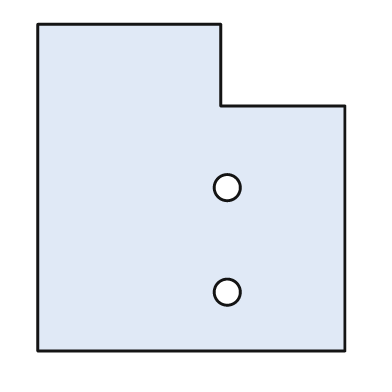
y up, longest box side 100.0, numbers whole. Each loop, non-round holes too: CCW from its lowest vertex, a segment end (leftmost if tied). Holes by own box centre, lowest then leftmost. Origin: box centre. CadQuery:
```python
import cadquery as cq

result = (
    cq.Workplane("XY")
    .moveTo(-47.0, -50.0)
    .lineTo(47.0, -50.0)
    .lineTo(47.0, 25.0)
    .lineTo(9.0, 25.0)
    .lineTo(9.0, 50.0)
    .lineTo(-47.0, 50.0)
    .close()
    .moveTo(11.0, -32.0)
    .circle(4.0)
    .moveTo(11.0, 0.0)
    .circle(4.0)
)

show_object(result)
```